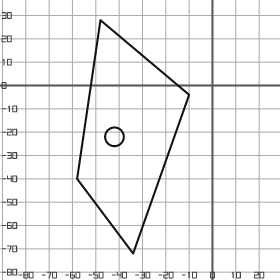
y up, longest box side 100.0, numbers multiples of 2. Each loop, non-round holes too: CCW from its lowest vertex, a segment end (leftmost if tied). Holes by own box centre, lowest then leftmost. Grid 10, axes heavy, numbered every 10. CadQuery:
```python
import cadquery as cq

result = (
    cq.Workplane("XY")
    .moveTo(-34.0, -72.0)
    .lineTo(-10.0, -4.0)
    .lineTo(-48.0, 28.0)
    .lineTo(-58.0, -40.0)
    .close()
    .moveTo(-42.0, -22.0)
    .circle(4.0)
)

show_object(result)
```